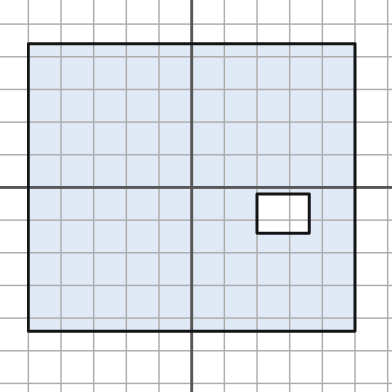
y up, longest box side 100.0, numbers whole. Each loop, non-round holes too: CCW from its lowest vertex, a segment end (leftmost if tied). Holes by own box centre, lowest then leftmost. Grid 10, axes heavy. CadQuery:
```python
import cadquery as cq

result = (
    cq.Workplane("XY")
    .moveTo(-50.0, -44.0)
    .lineTo(50.0, -44.0)
    .lineTo(50.0, 44.0)
    .lineTo(-50.0, 44.0)
    .close()
    .moveTo(20.0, -14.0)
    .lineTo(36.0, -14.0)
    .lineTo(36.0, -2.0)
    .lineTo(20.0, -2.0)
    .close()
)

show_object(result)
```